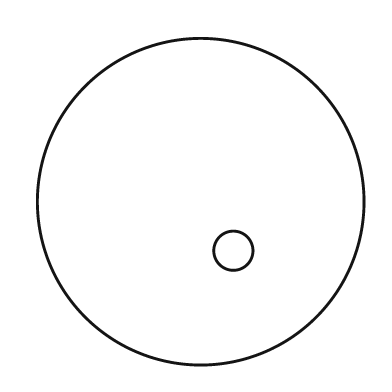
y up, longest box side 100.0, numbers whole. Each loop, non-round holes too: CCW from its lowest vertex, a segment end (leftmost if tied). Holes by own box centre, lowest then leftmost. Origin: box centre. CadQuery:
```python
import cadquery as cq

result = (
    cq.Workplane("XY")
    .moveTo(0.0, 0.0)
    .circle(50.0)
    .moveTo(10.0, -15.0)
    .circle(6.0)
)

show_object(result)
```